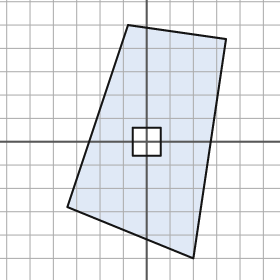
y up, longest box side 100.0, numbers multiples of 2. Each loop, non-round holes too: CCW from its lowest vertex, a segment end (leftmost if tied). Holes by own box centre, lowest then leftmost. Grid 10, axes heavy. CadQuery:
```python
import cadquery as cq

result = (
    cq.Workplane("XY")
    .moveTo(20.0, -50.0)
    .lineTo(34.0, 44.0)
    .lineTo(-8.0, 50.0)
    .lineTo(-34.0, -28.0)
    .close()
    .moveTo(-6.0, -6.0)
    .lineTo(6.0, -6.0)
    .lineTo(6.0, 6.0)
    .lineTo(-6.0, 6.0)
    .close()
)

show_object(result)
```